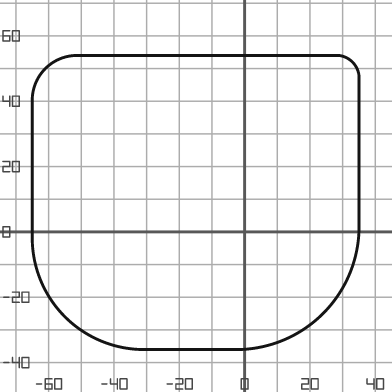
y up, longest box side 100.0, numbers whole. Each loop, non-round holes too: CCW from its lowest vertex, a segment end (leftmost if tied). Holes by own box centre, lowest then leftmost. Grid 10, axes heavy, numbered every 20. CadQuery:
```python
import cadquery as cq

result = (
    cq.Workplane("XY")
    .moveTo(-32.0, -36.0)
    .lineTo(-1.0, -36.0)
    .threePointArc((24.0, -25.0), (35.0, 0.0))
    .lineTo(35.0, 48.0)
    .threePointArc((33.0, 52.0), (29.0, 54.0))
    .lineTo(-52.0, 54.0)
    .threePointArc((-61.0, 50.0), (-65.0, 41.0))
    .lineTo(-65.0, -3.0)
    .threePointArc((-55.0, -26.0), (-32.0, -36.0))
    .close()
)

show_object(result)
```